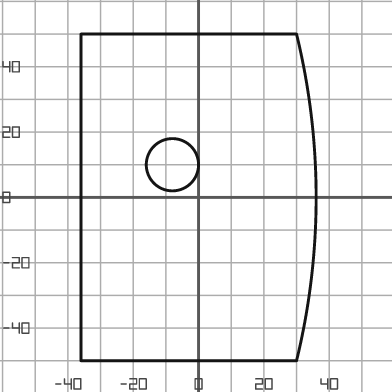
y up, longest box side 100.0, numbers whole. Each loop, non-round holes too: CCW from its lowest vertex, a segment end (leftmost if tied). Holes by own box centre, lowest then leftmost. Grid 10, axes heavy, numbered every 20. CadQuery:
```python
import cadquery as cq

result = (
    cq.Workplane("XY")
    .moveTo(-36.0, -50.0)
    .lineTo(30.0, -50.0)
    .threePointArc((36.0, 0.0), (30.0, 50.0))
    .lineTo(-36.0, 50.0)
    .close()
    .moveTo(-8.0, 10.0)
    .circle(8.0)
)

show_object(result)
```